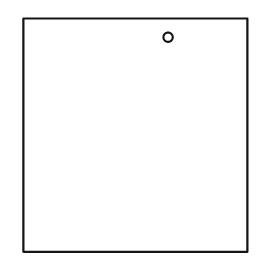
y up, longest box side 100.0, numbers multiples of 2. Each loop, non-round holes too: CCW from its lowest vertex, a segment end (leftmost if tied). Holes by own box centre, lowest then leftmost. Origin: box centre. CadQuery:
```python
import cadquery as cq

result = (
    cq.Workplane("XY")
    .moveTo(-48.0, -50.0)
    .lineTo(48.0, -50.0)
    .lineTo(48.0, 50.0)
    .lineTo(-48.0, 50.0)
    .close()
    .moveTo(14.0, 42.0)
    .circle(2.0)
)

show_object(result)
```